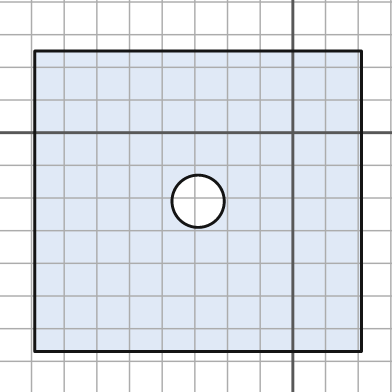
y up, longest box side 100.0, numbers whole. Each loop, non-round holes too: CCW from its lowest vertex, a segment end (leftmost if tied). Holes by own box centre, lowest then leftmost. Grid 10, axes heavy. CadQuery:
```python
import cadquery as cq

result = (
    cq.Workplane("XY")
    .moveTo(-79.0, -67.0)
    .lineTo(21.0, -67.0)
    .lineTo(21.0, 25.0)
    .lineTo(-79.0, 25.0)
    .close()
    .moveTo(-29.0, -21.0)
    .circle(8.0)
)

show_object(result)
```